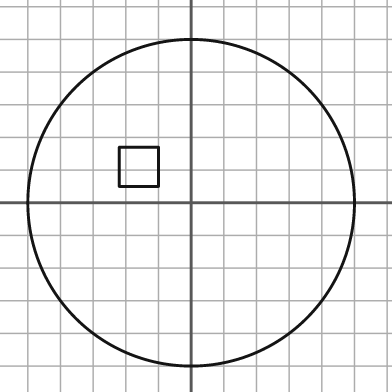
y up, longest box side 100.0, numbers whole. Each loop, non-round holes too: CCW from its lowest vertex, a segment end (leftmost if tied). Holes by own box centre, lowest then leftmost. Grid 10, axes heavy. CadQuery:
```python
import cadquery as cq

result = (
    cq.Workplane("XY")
    .moveTo(0.0, 0.0)
    .circle(50.0)
    .moveTo(-22.0, 5.0)
    .lineTo(-10.0, 5.0)
    .lineTo(-10.0, 17.0)
    .lineTo(-22.0, 17.0)
    .close()
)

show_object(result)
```